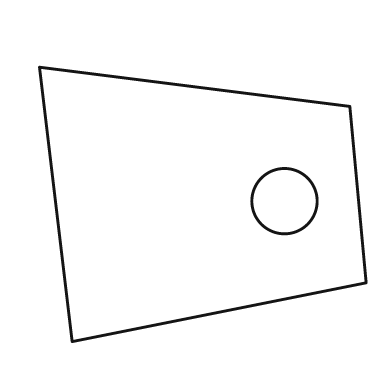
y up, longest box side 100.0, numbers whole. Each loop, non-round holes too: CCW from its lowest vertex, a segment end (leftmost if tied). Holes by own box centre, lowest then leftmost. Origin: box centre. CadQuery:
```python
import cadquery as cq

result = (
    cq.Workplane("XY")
    .moveTo(-40.0, -42.0)
    .lineTo(50.0, -24.0)
    .lineTo(45.0, 30.0)
    .lineTo(-50.0, 42.0)
    .close()
    .moveTo(25.0, 1.0)
    .circle(10.0)
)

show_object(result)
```